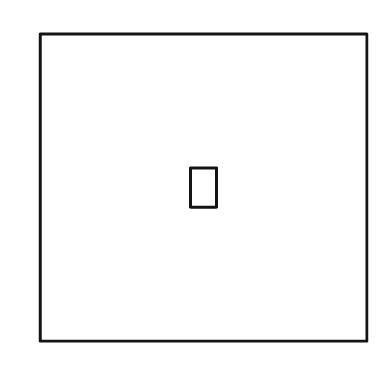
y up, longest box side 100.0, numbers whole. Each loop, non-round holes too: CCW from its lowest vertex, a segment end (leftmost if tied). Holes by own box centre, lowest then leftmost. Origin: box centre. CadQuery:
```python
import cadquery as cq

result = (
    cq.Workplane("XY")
    .moveTo(-50.0, -47.0)
    .lineTo(50.0, -47.0)
    .lineTo(50.0, 47.0)
    .lineTo(-50.0, 47.0)
    .close()
    .moveTo(-4.0, -6.0)
    .lineTo(4.0, -6.0)
    .lineTo(4.0, 6.0)
    .lineTo(-4.0, 6.0)
    .close()
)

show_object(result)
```